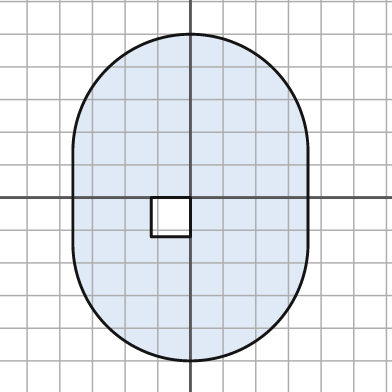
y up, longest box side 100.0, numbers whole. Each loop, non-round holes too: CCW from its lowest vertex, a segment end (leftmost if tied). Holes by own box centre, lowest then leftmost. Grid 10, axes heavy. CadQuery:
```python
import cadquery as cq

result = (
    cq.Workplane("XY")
    .moveTo(-36.0, -14.0)
    .threePointArc((0.0, -50.0), (36.0, -14.0))
    .lineTo(36.0, 14.0)
    .threePointArc((0.0, 50.0), (-36.0, 14.0))
    .close()
    .moveTo(-12.0, -12.0)
    .lineTo(0.0, -12.0)
    .lineTo(0.0, 0.0)
    .lineTo(-12.0, 0.0)
    .close()
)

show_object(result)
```